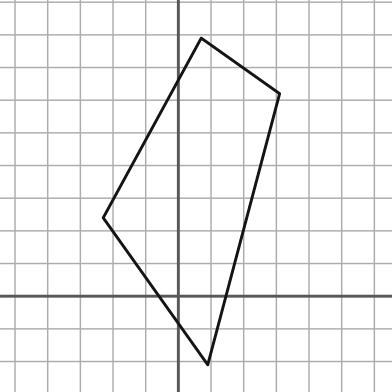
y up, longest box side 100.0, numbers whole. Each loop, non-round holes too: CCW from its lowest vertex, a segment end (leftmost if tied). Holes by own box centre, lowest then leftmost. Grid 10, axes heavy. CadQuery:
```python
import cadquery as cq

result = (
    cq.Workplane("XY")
    .moveTo(9.0, -21.0)
    .lineTo(31.0, 62.0)
    .lineTo(7.0, 79.0)
    .lineTo(-23.0, 24.0)
    .close()
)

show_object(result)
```